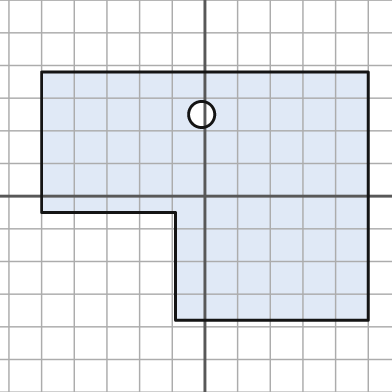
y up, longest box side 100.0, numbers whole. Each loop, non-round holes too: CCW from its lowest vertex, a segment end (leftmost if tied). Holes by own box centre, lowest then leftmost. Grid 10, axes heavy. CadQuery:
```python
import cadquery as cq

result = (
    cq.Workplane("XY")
    .moveTo(-9.0, -38.0)
    .lineTo(50.0, -38.0)
    .lineTo(50.0, 38.0)
    .lineTo(-50.0, 38.0)
    .lineTo(-50.0, -5.0)
    .lineTo(-9.0, -5.0)
    .close()
    .moveTo(-1.0, 25.0)
    .circle(4.0)
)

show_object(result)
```